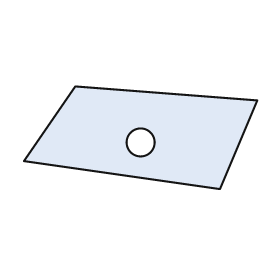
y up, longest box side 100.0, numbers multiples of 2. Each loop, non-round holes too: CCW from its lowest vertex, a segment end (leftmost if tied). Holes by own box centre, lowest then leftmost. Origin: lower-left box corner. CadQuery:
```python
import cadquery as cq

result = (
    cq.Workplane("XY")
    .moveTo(84.0, 0.0)
    .lineTo(100.0, 38.0)
    .lineTo(22.0, 44.0)
    .lineTo(0.0, 12.0)
    .close()
    .moveTo(50.0, 20.0)
    .circle(6.0)
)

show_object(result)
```